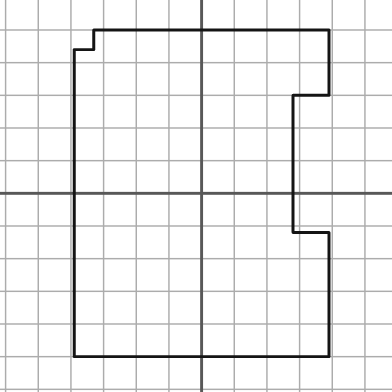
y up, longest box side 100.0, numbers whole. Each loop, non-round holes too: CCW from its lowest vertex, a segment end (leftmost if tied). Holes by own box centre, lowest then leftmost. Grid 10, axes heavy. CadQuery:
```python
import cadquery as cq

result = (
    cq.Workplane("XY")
    .moveTo(-39.0, -50.0)
    .lineTo(39.0, -50.0)
    .lineTo(39.0, -12.0)
    .lineTo(28.0, -12.0)
    .lineTo(28.0, 30.0)
    .lineTo(39.0, 30.0)
    .lineTo(39.0, 50.0)
    .lineTo(-33.0, 50.0)
    .lineTo(-33.0, 44.0)
    .lineTo(-39.0, 44.0)
    .close()
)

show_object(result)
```